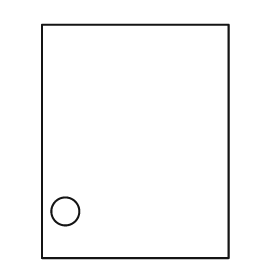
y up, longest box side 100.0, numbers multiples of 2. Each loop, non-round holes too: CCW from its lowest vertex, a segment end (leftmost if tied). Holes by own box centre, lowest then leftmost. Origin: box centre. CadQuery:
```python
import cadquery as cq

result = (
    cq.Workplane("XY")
    .moveTo(-40.0, -50.0)
    .lineTo(40.0, -50.0)
    .lineTo(40.0, 50.0)
    .lineTo(-40.0, 50.0)
    .close()
    .moveTo(-30.0, -30.0)
    .circle(6.0)
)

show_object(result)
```